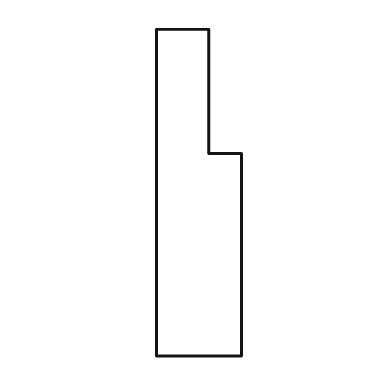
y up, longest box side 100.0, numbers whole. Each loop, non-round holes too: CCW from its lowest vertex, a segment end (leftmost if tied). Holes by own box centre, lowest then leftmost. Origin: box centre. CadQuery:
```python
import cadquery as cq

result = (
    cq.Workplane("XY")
    .moveTo(-13.0, -50.0)
    .lineTo(13.0, -50.0)
    .lineTo(13.0, 12.0)
    .lineTo(3.0, 12.0)
    .lineTo(3.0, 50.0)
    .lineTo(-13.0, 50.0)
    .close()
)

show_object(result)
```